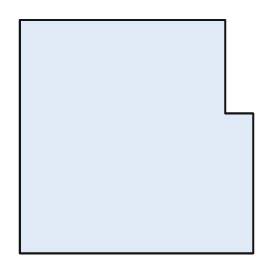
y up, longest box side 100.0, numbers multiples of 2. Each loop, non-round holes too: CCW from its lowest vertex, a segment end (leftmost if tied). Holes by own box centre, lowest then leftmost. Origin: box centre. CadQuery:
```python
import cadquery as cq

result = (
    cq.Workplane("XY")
    .moveTo(-50.0, -50.0)
    .lineTo(50.0, -50.0)
    .lineTo(50.0, 10.0)
    .lineTo(38.0, 10.0)
    .lineTo(38.0, 50.0)
    .lineTo(-50.0, 50.0)
    .close()
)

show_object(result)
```